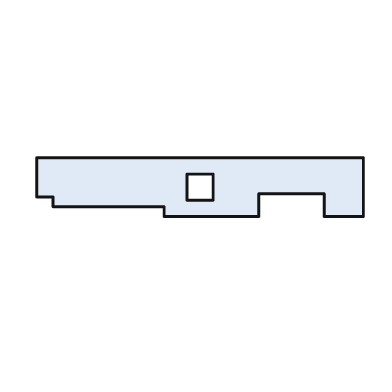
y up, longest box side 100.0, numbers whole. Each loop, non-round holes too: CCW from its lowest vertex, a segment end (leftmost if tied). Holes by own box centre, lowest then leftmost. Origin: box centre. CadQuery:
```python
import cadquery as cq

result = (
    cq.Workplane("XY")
    .moveTo(-11.0, -9.0)
    .lineTo(18.0, -9.0)
    .lineTo(18.0, -2.0)
    .lineTo(38.0, -2.0)
    .lineTo(38.0, -9.0)
    .lineTo(50.0, -9.0)
    .lineTo(50.0, 9.0)
    .lineTo(-50.0, 9.0)
    .lineTo(-50.0, -3.0)
    .lineTo(-45.0, -3.0)
    .lineTo(-45.0, -6.0)
    .lineTo(-11.0, -6.0)
    .close()
    .moveTo(-4.0, -4.0)
    .lineTo(4.0, -4.0)
    .lineTo(4.0, 4.0)
    .lineTo(-4.0, 4.0)
    .close()
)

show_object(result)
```